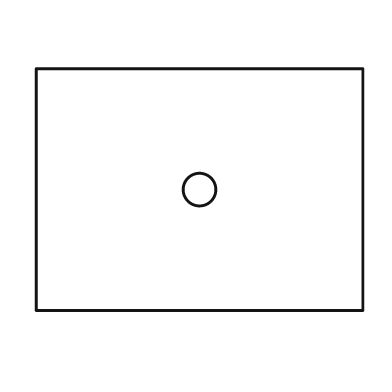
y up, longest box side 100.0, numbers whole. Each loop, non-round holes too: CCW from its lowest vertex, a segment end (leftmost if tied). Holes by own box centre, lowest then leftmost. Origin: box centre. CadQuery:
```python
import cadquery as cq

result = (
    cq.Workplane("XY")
    .moveTo(-50.0, -37.0)
    .lineTo(50.0, -37.0)
    .lineTo(50.0, 37.0)
    .lineTo(-50.0, 37.0)
    .close()
    .moveTo(0.0, 0.0)
    .circle(5.0)
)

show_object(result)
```